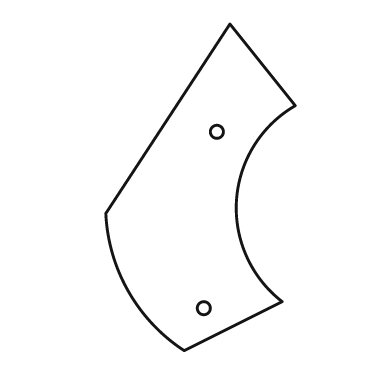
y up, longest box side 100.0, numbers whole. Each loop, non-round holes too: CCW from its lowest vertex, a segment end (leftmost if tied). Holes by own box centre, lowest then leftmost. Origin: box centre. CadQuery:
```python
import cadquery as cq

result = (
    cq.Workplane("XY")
    .moveTo(-5.0, -50.0)
    .lineTo(25.0, -35.0)
    .threePointArc((11.0, -4.0), (29.0, 25.0))
    .lineTo(9.0, 50.0)
    .lineTo(-29.0, -8.0)
    .threePointArc((-22.0, -32.0), (-5.0, -50.0))
    .close()
    .moveTo(1.0, -37.0)
    .circle(2.0)
    .moveTo(5.0, 17.0)
    .circle(2.0)
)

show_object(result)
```